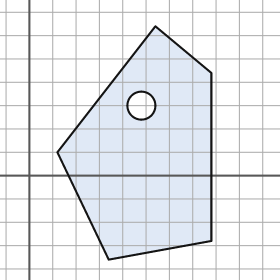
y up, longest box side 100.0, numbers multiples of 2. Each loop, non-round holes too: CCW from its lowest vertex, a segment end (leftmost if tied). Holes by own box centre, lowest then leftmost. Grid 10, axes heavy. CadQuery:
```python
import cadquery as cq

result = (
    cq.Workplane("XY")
    .moveTo(34.0, -36.0)
    .lineTo(78.0, -28.0)
    .lineTo(78.0, 44.0)
    .lineTo(54.0, 64.0)
    .lineTo(12.0, 10.0)
    .close()
    .moveTo(48.0, 30.0)
    .circle(6.0)
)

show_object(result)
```